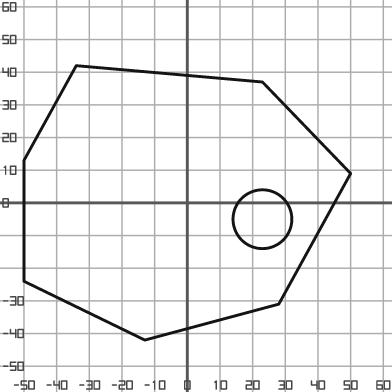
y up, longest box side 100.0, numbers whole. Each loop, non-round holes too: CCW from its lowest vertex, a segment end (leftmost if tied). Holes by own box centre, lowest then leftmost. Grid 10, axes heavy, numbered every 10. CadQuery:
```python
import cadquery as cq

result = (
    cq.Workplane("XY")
    .moveTo(-13.0, -42.0)
    .lineTo(28.0, -31.0)
    .lineTo(50.0, 9.0)
    .lineTo(23.0, 37.0)
    .lineTo(-34.0, 42.0)
    .lineTo(-50.0, 13.0)
    .lineTo(-50.0, -24.0)
    .close()
    .moveTo(23.0, -5.0)
    .circle(9.0)
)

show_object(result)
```